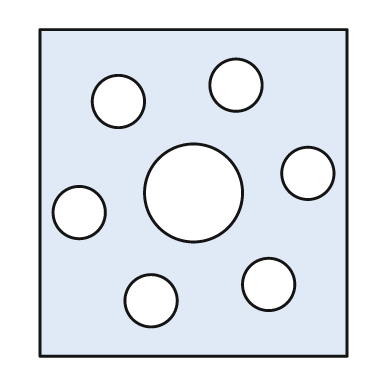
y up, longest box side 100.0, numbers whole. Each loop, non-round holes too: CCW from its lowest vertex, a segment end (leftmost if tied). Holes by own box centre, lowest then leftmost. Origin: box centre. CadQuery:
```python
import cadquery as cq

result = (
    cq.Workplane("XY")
    .moveTo(-47.0, -50.0)
    .lineTo(47.0, -50.0)
    .lineTo(47.0, 50.0)
    .lineTo(-47.0, 50.0)
    .close()
    .moveTo(-13.0, -33.0)
    .circle(8.0)
    .moveTo(23.0, -28.0)
    .circle(8.0)
    .moveTo(-35.0, -6.0)
    .circle(8.0)
    .moveTo(0.0, 0.0)
    .circle(15.0)
    .moveTo(35.0, 6.0)
    .circle(8.0)
    .moveTo(-23.0, 28.0)
    .circle(8.0)
    .moveTo(13.0, 33.0)
    .circle(8.0)
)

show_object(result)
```